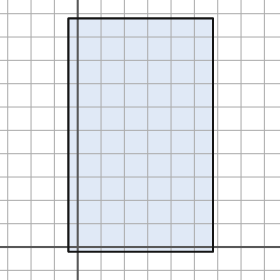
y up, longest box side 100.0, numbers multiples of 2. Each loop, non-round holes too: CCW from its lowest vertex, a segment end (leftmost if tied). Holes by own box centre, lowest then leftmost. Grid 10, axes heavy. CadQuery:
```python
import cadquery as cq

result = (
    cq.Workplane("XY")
    .moveTo(-4.0, -2.0)
    .lineTo(58.0, -2.0)
    .lineTo(58.0, 98.0)
    .lineTo(-4.0, 98.0)
    .close()
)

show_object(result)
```